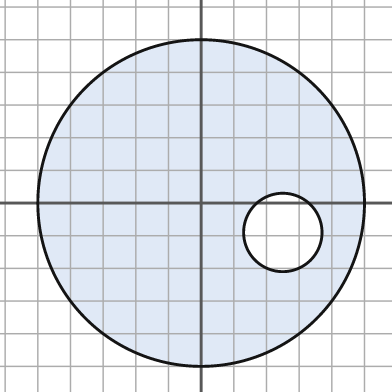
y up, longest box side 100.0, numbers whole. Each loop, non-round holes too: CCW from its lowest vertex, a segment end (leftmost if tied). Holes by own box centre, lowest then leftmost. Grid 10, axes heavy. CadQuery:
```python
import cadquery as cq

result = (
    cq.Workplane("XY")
    .moveTo(0.0, 0.0)
    .circle(50.0)
    .moveTo(25.0, -9.0)
    .circle(12.0)
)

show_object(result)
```